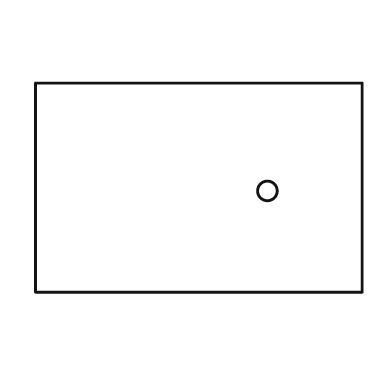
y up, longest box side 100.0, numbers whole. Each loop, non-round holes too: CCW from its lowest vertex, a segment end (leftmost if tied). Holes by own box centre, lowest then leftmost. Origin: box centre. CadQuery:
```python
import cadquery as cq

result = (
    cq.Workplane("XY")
    .moveTo(-50.0, -32.0)
    .lineTo(50.0, -32.0)
    .lineTo(50.0, 32.0)
    .lineTo(-50.0, 32.0)
    .close()
    .moveTo(21.0, -1.0)
    .circle(3.0)
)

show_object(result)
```